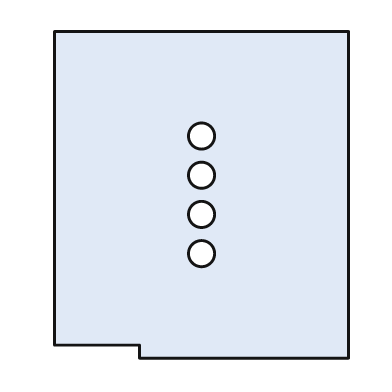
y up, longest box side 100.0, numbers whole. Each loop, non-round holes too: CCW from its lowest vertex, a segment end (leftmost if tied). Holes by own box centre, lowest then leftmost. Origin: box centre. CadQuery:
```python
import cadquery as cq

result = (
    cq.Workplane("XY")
    .moveTo(-19.0, -50.0)
    .lineTo(45.0, -50.0)
    .lineTo(45.0, 50.0)
    .lineTo(-45.0, 50.0)
    .lineTo(-45.0, -46.0)
    .lineTo(-19.0, -46.0)
    .close()
    .moveTo(0.0, -18.0)
    .circle(4.0)
    .moveTo(0.0, -6.0)
    .circle(4.0)
    .moveTo(0.0, 6.0)
    .circle(4.0)
    .moveTo(0.0, 18.0)
    .circle(4.0)
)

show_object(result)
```